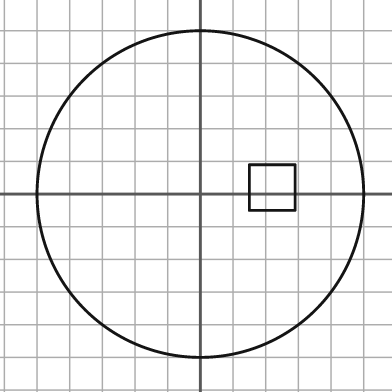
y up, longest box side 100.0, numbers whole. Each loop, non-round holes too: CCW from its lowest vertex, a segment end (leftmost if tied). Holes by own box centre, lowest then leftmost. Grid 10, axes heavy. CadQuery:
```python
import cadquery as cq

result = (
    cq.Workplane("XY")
    .moveTo(0.0, 0.0)
    .circle(50.0)
    .moveTo(15.0, -5.0)
    .lineTo(29.0, -5.0)
    .lineTo(29.0, 9.0)
    .lineTo(15.0, 9.0)
    .close()
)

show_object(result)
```